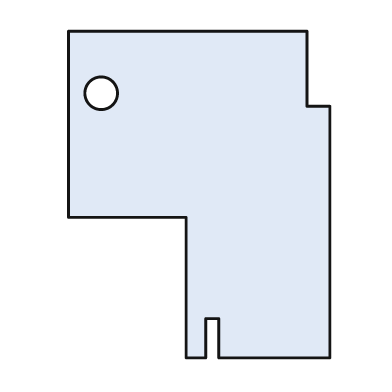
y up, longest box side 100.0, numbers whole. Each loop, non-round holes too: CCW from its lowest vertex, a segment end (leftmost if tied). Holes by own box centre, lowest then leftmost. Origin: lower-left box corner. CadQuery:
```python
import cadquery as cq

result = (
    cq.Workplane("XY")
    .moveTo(36.0, 0.0)
    .lineTo(42.0, 0.0)
    .lineTo(42.0, 12.0)
    .lineTo(46.0, 12.0)
    .lineTo(46.0, 0.0)
    .lineTo(80.0, 0.0)
    .lineTo(80.0, 77.0)
    .lineTo(73.0, 77.0)
    .lineTo(73.0, 100.0)
    .lineTo(0.0, 100.0)
    .lineTo(0.0, 43.0)
    .lineTo(36.0, 43.0)
    .close()
    .moveTo(10.0, 81.0)
    .circle(5.0)
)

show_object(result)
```